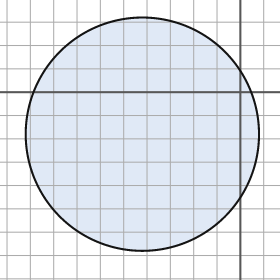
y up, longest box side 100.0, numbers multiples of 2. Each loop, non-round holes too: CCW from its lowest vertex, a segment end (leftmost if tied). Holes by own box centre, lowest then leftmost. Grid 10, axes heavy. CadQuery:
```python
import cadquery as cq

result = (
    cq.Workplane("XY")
    .moveTo(-42.0, -18.0)
    .circle(50.0)
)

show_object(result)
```